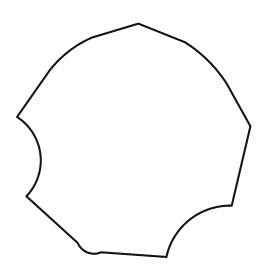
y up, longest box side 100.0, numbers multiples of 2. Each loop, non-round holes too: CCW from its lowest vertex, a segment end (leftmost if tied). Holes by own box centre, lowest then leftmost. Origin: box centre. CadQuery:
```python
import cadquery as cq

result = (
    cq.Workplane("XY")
    .moveTo(14.0, -50.0)
    .threePointArc((24.0, -34.0), (42.0, -28.0))
    .lineTo(50.0, 6.0)
    .lineTo(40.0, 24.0)
    .threePointArc((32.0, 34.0), (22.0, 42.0))
    .lineTo(2.0, 50.0)
    .lineTo(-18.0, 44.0)
    .threePointArc((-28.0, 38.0), (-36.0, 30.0))
    .lineTo(-50.0, 10.0)
    .threePointArc((-40.0, -6.0), (-46.0, -24.0))
    .lineTo(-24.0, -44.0)
    .threePointArc((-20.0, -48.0), (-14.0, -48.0))
    .close()
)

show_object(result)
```